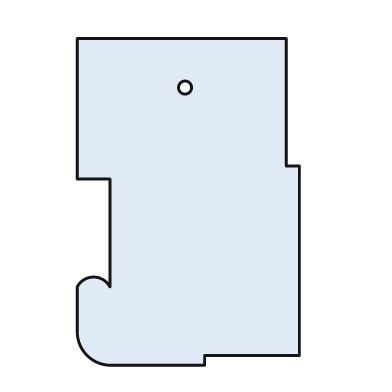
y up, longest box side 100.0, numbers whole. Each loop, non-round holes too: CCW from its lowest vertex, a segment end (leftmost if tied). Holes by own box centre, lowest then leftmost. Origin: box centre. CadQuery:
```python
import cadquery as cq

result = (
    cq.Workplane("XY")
    .moveTo(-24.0, -50.0)
    .lineTo(5.0, -50.0)
    .lineTo(5.0, -47.0)
    .lineTo(34.0, -47.0)
    .lineTo(34.0, 11.0)
    .lineTo(30.0, 11.0)
    .lineTo(30.0, 50.0)
    .lineTo(-34.0, 50.0)
    .lineTo(-34.0, 7.0)
    .lineTo(-24.0, 7.0)
    .lineTo(-24.0, -26.0)
    .threePointArc((-29.0, -23.0), (-34.0, -26.0))
    .lineTo(-34.0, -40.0)
    .threePointArc((-31.0, -47.0), (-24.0, -50.0))
    .close()
    .moveTo(-1.0, 35.0)
    .circle(2.0)
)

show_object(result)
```